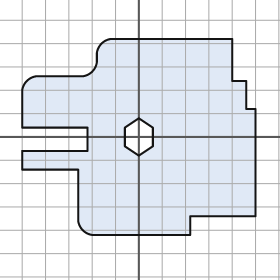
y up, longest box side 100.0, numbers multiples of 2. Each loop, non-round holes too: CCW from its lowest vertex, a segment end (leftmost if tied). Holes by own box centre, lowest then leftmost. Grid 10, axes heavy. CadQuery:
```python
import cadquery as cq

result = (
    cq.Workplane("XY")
    .moveTo(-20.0, -42.0)
    .lineTo(22.0, -42.0)
    .lineTo(22.0, -34.0)
    .lineTo(50.0, -34.0)
    .lineTo(50.0, 12.0)
    .lineTo(46.0, 12.0)
    .lineTo(46.0, 24.0)
    .lineTo(40.0, 24.0)
    .lineTo(40.0, 42.0)
    .lineTo(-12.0, 42.0)
    .threePointArc((-16.0, 40.0), (-18.0, 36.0))
    .lineTo(-18.0, 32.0)
    .threePointArc((-20.0, 28.0), (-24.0, 26.0))
    .lineTo(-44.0, 26.0)
    .threePointArc((-48.0, 24.0), (-50.0, 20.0))
    .lineTo(-50.0, 4.0)
    .lineTo(-22.0, 4.0)
    .lineTo(-22.0, -6.0)
    .lineTo(-50.0, -6.0)
    .lineTo(-50.0, -14.0)
    .lineTo(-26.0, -14.0)
    .lineTo(-26.0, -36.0)
    .threePointArc((-24.0, -40.0), (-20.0, -42.0))
    .close()
    .moveTo(0.0, -8.0)
    .lineTo(6.0, -4.0)
    .lineTo(6.0, 4.0)
    .lineTo(0.0, 8.0)
    .lineTo(-6.0, 4.0)
    .lineTo(-6.0, -4.0)
    .close()
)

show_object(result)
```